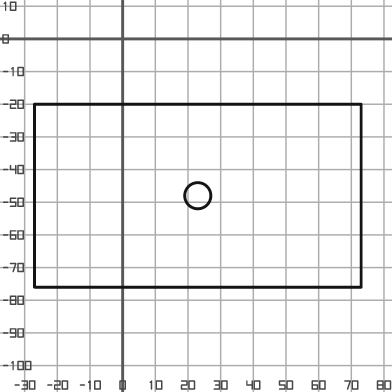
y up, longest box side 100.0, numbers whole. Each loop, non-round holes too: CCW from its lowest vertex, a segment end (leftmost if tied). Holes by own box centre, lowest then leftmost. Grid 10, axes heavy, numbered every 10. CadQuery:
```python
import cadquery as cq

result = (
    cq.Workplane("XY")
    .moveTo(-27.0, -76.0)
    .lineTo(73.0, -76.0)
    .lineTo(73.0, -20.0)
    .lineTo(-27.0, -20.0)
    .close()
    .moveTo(23.0, -48.0)
    .circle(4.0)
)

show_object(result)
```